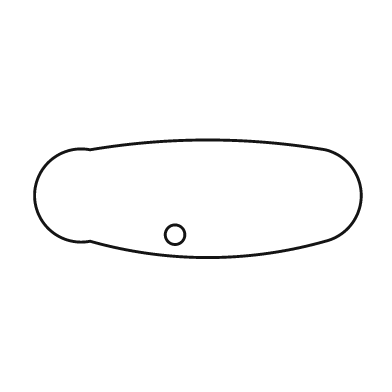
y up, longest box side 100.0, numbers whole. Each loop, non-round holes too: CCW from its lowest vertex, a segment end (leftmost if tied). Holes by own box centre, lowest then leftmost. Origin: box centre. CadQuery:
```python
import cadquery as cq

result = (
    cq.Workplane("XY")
    .moveTo(-33.0, -13.0)
    .threePointArc((3.0, -18.0), (39.0, -13.0))
    .threePointArc((50.0, 1.0), (39.0, 15.0))
    .threePointArc((3.0, 18.0), (-33.0, 15.0))
    .threePointArc((-50.0, 1.0), (-33.0, -13.0))
    .close()
    .moveTo(-7.0, -11.0)
    .circle(3.0)
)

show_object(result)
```